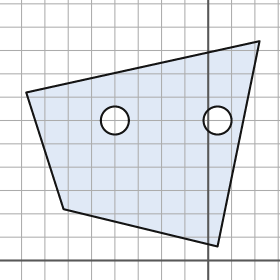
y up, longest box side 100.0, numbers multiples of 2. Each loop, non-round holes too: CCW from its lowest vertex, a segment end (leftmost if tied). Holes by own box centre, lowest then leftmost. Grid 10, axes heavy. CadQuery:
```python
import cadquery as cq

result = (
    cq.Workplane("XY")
    .moveTo(4.0, 6.0)
    .lineTo(22.0, 94.0)
    .lineTo(-78.0, 72.0)
    .lineTo(-62.0, 22.0)
    .close()
    .moveTo(-40.0, 60.0)
    .circle(6.0)
    .moveTo(4.0, 60.0)
    .circle(6.0)
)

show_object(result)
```